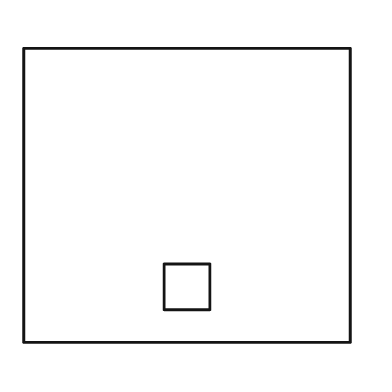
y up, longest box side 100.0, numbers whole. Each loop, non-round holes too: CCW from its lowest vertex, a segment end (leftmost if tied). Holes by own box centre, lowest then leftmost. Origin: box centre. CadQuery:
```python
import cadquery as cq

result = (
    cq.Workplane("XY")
    .moveTo(-50.0, -45.0)
    .lineTo(50.0, -45.0)
    .lineTo(50.0, 45.0)
    .lineTo(-50.0, 45.0)
    .close()
    .moveTo(-7.0, -35.0)
    .lineTo(7.0, -35.0)
    .lineTo(7.0, -21.0)
    .lineTo(-7.0, -21.0)
    .close()
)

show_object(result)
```